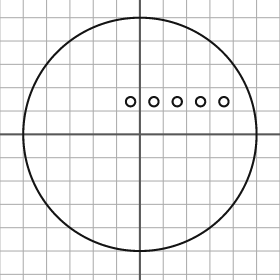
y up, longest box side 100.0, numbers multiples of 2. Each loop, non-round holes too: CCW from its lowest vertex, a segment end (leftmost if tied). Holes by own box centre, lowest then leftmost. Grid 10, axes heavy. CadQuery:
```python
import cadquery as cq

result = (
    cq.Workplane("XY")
    .moveTo(0.0, 0.0)
    .circle(50.0)
    .moveTo(-4.0, 14.0)
    .circle(2.0)
    .moveTo(6.0, 14.0)
    .circle(2.0)
    .moveTo(16.0, 14.0)
    .circle(2.0)
    .moveTo(26.0, 14.0)
    .circle(2.0)
    .moveTo(36.0, 14.0)
    .circle(2.0)
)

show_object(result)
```